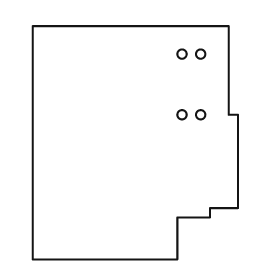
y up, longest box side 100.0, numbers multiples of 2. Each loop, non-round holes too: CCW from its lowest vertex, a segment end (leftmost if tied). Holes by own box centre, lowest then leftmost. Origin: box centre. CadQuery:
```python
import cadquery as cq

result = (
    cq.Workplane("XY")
    .moveTo(-44.0, -50.0)
    .lineTo(18.0, -50.0)
    .lineTo(18.0, -32.0)
    .lineTo(32.0, -32.0)
    .lineTo(32.0, -28.0)
    .lineTo(44.0, -28.0)
    .lineTo(44.0, 12.0)
    .lineTo(40.0, 12.0)
    .lineTo(40.0, 50.0)
    .lineTo(-44.0, 50.0)
    .close()
    .moveTo(20.0, 12.0)
    .circle(2.0)
    .moveTo(28.0, 12.0)
    .circle(2.0)
    .moveTo(20.0, 38.0)
    .circle(2.0)
    .moveTo(28.0, 38.0)
    .circle(2.0)
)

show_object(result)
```